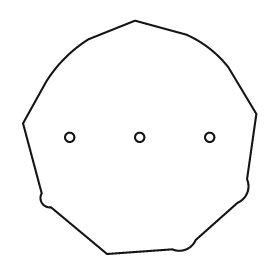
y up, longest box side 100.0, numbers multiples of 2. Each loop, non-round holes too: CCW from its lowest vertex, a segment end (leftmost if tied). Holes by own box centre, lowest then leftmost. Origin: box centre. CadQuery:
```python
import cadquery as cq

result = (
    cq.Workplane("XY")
    .moveTo(-14.0, -50.0)
    .lineTo(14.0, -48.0)
    .threePointArc((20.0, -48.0), (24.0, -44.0))
    .lineTo(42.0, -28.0)
    .threePointArc((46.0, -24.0), (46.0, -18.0))
    .lineTo(50.0, 10.0)
    .lineTo(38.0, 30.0)
    .threePointArc((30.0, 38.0), (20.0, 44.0))
    .lineTo(-2.0, 50.0)
    .lineTo(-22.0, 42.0)
    .threePointArc((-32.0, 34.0), (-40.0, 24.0))
    .lineTo(-50.0, 6.0)
    .lineTo(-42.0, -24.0)
    .threePointArc((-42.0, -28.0), (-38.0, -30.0))
    .close()
    .moveTo(-30.0, 0.0)
    .circle(2.0)
    .moveTo(0.0, 0.0)
    .circle(2.0)
    .moveTo(30.0, 0.0)
    .circle(2.0)
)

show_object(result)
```